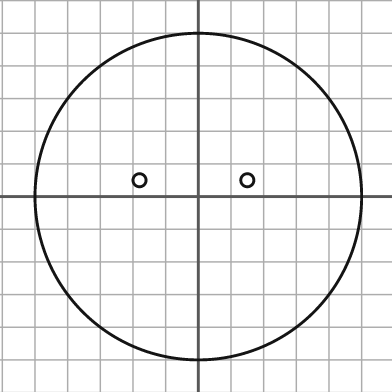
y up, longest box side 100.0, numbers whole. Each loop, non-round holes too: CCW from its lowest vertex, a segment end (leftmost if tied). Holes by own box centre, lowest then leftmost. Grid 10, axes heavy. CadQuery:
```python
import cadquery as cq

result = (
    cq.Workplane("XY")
    .moveTo(0.0, 0.0)
    .circle(50.0)
    .moveTo(-18.0, 5.0)
    .circle(2.0)
    .moveTo(15.0, 5.0)
    .circle(2.0)
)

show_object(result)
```